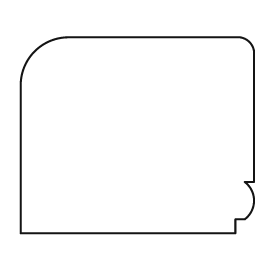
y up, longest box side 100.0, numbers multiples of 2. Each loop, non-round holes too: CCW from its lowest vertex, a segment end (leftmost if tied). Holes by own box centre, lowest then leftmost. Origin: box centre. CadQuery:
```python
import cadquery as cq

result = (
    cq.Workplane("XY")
    .moveTo(-50.0, -42.0)
    .lineTo(42.0, -42.0)
    .lineTo(42.0, -36.0)
    .lineTo(46.0, -36.0)
    .threePointArc((50.0, -28.0), (46.0, -20.0))
    .lineTo(50.0, -20.0)
    .lineTo(50.0, 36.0)
    .threePointArc((48.0, 40.0), (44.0, 42.0))
    .lineTo(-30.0, 42.0)
    .threePointArc((-44.0, 36.0), (-50.0, 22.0))
    .close()
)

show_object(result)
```